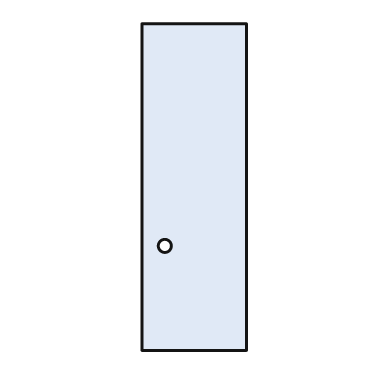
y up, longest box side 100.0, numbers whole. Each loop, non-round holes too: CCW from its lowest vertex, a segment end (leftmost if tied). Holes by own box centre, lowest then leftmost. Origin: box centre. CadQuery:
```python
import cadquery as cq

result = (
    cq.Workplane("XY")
    .moveTo(-16.0, -50.0)
    .lineTo(16.0, -50.0)
    .lineTo(16.0, 50.0)
    .lineTo(-16.0, 50.0)
    .close()
    .moveTo(-9.0, -18.0)
    .circle(2.0)
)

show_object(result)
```